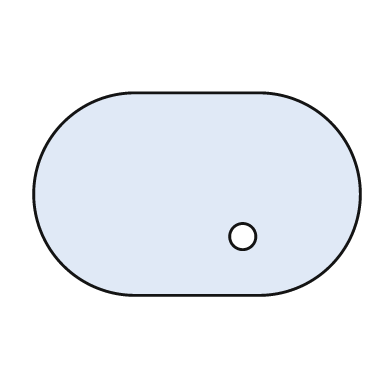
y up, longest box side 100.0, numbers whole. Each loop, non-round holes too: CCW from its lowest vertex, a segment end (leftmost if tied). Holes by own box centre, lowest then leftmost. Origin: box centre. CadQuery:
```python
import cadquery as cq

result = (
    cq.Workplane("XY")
    .moveTo(-19.0, -31.0)
    .lineTo(19.0, -31.0)
    .threePointArc((50.0, 0.0), (19.0, 31.0))
    .lineTo(-19.0, 31.0)
    .threePointArc((-50.0, 0.0), (-19.0, -31.0))
    .close()
    .moveTo(14.0, -13.0)
    .circle(4.0)
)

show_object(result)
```